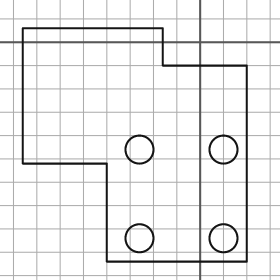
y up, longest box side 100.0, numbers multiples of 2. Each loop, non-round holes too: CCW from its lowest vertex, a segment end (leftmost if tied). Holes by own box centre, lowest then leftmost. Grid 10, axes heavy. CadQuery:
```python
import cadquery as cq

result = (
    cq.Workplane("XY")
    .moveTo(-40.0, -94.0)
    .lineTo(20.0, -94.0)
    .lineTo(20.0, -10.0)
    .lineTo(-16.0, -10.0)
    .lineTo(-16.0, 6.0)
    .lineTo(-76.0, 6.0)
    .lineTo(-76.0, -52.0)
    .lineTo(-40.0, -52.0)
    .close()
    .moveTo(-26.0, -84.0)
    .circle(6.0)
    .moveTo(10.0, -84.0)
    .circle(6.0)
    .moveTo(-26.0, -46.0)
    .circle(6.0)
    .moveTo(10.0, -46.0)
    .circle(6.0)
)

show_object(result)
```